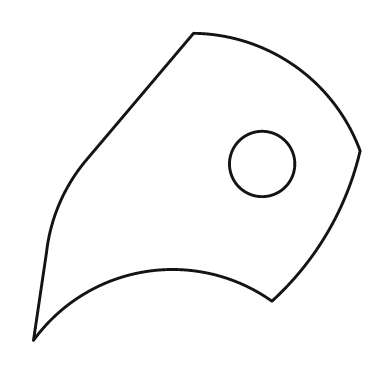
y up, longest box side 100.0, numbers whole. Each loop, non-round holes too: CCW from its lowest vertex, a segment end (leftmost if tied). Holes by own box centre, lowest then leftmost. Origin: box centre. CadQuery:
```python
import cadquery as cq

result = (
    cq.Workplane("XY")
    .moveTo(-50.0, -47.0)
    .threePointArc((-16.0, -26.0), (23.0, -35.0))
    .threePointArc((40.0, -14.0), (50.0, 11.0))
    .threePointArc((30.0, 37.0), (-1.0, 47.0))
    .lineTo(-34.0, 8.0)
    .threePointArc((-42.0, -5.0), (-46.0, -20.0))
    .close()
    .moveTo(20.0, 7.0)
    .circle(10.0)
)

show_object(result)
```